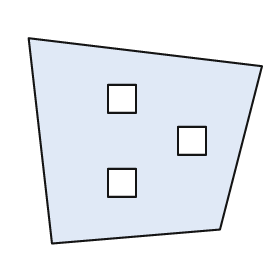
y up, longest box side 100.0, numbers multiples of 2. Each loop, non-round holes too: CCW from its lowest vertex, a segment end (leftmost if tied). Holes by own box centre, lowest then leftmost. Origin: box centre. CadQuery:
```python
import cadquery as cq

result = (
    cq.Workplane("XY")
    .moveTo(-40.0, -44.0)
    .lineTo(32.0, -38.0)
    .lineTo(50.0, 32.0)
    .lineTo(-50.0, 44.0)
    .close()
    .moveTo(-16.0, -24.0)
    .lineTo(-4.0, -24.0)
    .lineTo(-4.0, -12.0)
    .lineTo(-16.0, -12.0)
    .close()
    .moveTo(14.0, -6.0)
    .lineTo(26.0, -6.0)
    .lineTo(26.0, 6.0)
    .lineTo(14.0, 6.0)
    .close()
    .moveTo(-16.0, 12.0)
    .lineTo(-4.0, 12.0)
    .lineTo(-4.0, 24.0)
    .lineTo(-16.0, 24.0)
    .close()
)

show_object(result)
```